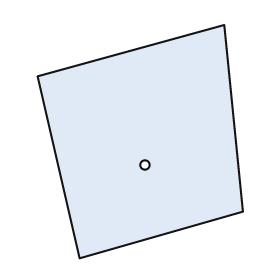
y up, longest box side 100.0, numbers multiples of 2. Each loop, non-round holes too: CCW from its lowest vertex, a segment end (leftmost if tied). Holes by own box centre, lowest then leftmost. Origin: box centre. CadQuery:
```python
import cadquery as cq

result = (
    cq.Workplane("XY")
    .moveTo(-26.0, -50.0)
    .lineTo(44.0, -30.0)
    .lineTo(36.0, 50.0)
    .lineTo(-44.0, 28.0)
    .close()
    .moveTo(2.0, -10.0)
    .circle(2.0)
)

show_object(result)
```